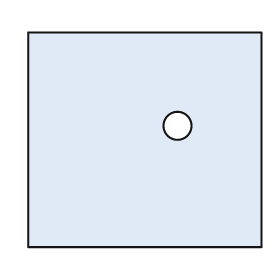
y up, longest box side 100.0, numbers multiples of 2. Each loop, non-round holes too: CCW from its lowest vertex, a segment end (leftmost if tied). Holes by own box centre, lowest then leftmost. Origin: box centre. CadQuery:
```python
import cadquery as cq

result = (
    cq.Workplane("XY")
    .moveTo(-50.0, -46.0)
    .lineTo(50.0, -46.0)
    .lineTo(50.0, 46.0)
    .lineTo(-50.0, 46.0)
    .close()
    .moveTo(14.0, 6.0)
    .circle(6.0)
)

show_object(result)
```